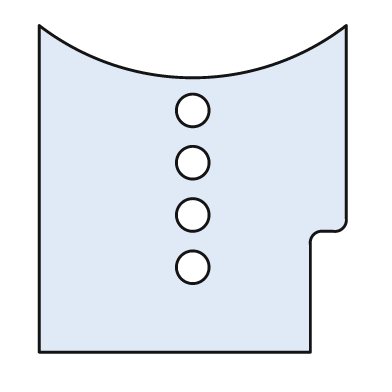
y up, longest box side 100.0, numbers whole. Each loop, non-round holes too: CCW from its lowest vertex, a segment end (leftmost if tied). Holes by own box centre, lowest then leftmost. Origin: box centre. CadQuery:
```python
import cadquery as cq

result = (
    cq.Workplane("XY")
    .moveTo(-47.0, -50.0)
    .lineTo(36.0, -50.0)
    .lineTo(36.0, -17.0)
    .threePointArc((37.0, -14.0), (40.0, -13.0))
    .lineTo(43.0, -13.0)
    .threePointArc((46.0, -12.0), (47.0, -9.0))
    .lineTo(47.0, 50.0)
    .threePointArc((0.0, 34.0), (-47.0, 50.0))
    .close()
    .moveTo(0.0, -24.0)
    .circle(5.0)
    .moveTo(0.0, -8.0)
    .circle(5.0)
    .moveTo(0.0, 8.0)
    .circle(5.0)
    .moveTo(0.0, 24.0)
    .circle(5.0)
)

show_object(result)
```